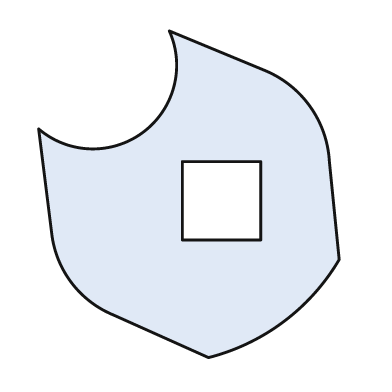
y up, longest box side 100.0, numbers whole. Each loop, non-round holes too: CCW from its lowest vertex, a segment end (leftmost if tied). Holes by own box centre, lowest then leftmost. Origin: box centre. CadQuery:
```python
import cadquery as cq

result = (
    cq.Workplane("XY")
    .moveTo(6.0, -50.0)
    .threePointArc((29.0, -39.0), (46.0, -20.0))
    .lineTo(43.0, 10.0)
    .threePointArc((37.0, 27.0), (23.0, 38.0))
    .lineTo(-6.0, 50.0)
    .threePointArc((-14.0, 19.0), (-46.0, 20.0))
    .lineTo(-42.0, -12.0)
    .threePointArc((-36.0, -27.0), (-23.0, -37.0))
    .close()
    .moveTo(-2.0, -14.0)
    .lineTo(22.0, -14.0)
    .lineTo(22.0, 10.0)
    .lineTo(-2.0, 10.0)
    .close()
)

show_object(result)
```